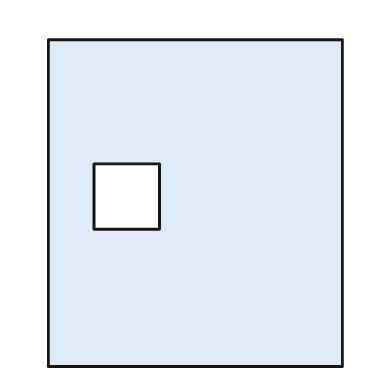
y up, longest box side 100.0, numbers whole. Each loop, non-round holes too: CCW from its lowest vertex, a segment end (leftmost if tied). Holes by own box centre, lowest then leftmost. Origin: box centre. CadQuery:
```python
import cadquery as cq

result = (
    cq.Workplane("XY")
    .moveTo(-45.0, -50.0)
    .lineTo(45.0, -50.0)
    .lineTo(45.0, 50.0)
    .lineTo(-45.0, 50.0)
    .close()
    .moveTo(-31.0, -8.0)
    .lineTo(-11.0, -8.0)
    .lineTo(-11.0, 12.0)
    .lineTo(-31.0, 12.0)
    .close()
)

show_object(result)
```